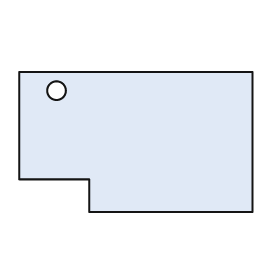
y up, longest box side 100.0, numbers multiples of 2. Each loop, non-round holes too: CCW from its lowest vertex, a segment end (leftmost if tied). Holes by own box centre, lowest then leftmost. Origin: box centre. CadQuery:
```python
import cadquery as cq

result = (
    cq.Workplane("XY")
    .moveTo(-20.0, -30.0)
    .lineTo(50.0, -30.0)
    .lineTo(50.0, 30.0)
    .lineTo(-50.0, 30.0)
    .lineTo(-50.0, -16.0)
    .lineTo(-20.0, -16.0)
    .close()
    .moveTo(-34.0, 22.0)
    .circle(4.0)
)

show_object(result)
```